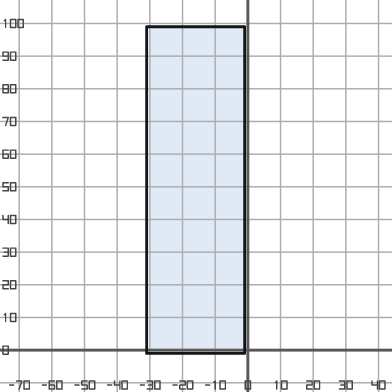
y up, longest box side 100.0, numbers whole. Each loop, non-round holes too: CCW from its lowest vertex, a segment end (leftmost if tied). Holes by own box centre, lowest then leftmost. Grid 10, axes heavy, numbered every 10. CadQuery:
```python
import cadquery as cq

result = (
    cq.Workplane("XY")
    .moveTo(-31.0, -1.0)
    .lineTo(-1.0, -1.0)
    .lineTo(-1.0, 99.0)
    .lineTo(-31.0, 99.0)
    .close()
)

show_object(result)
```